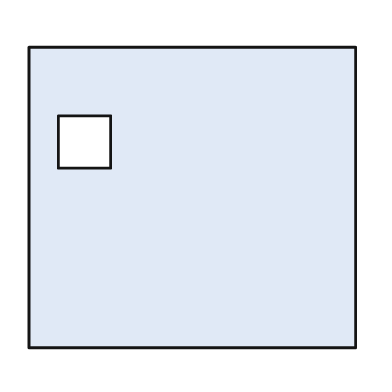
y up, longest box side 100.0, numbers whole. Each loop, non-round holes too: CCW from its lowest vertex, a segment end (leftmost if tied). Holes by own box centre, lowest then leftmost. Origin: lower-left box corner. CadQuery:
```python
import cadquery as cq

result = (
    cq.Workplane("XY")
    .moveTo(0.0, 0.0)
    .lineTo(100.0, 0.0)
    .lineTo(100.0, 92.0)
    .lineTo(0.0, 92.0)
    .close()
    .moveTo(9.0, 55.0)
    .lineTo(25.0, 55.0)
    .lineTo(25.0, 71.0)
    .lineTo(9.0, 71.0)
    .close()
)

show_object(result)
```